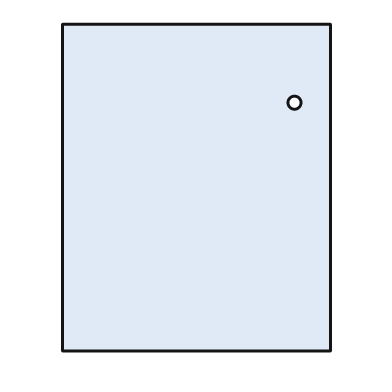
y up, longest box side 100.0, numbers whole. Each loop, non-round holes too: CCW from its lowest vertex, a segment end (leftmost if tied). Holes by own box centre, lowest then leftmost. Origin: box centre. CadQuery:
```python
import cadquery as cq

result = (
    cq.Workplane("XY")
    .moveTo(-41.0, -50.0)
    .lineTo(41.0, -50.0)
    .lineTo(41.0, 50.0)
    .lineTo(-41.0, 50.0)
    .close()
    .moveTo(30.0, 26.0)
    .circle(2.0)
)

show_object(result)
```